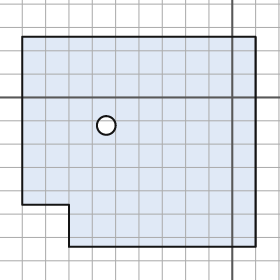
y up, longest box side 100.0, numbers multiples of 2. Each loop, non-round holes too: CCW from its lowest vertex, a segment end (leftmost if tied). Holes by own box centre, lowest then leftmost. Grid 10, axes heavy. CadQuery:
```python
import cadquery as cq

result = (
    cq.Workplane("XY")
    .moveTo(-70.0, -64.0)
    .lineTo(10.0, -64.0)
    .lineTo(10.0, 26.0)
    .lineTo(-90.0, 26.0)
    .lineTo(-90.0, -46.0)
    .lineTo(-70.0, -46.0)
    .close()
    .moveTo(-54.0, -12.0)
    .circle(4.0)
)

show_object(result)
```